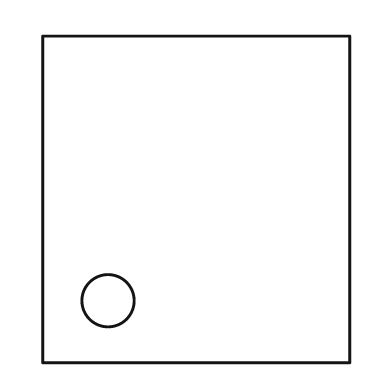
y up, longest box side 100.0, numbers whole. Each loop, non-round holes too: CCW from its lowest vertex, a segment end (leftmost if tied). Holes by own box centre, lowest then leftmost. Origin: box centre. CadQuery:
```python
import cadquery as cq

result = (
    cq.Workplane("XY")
    .moveTo(-47.0, -50.0)
    .lineTo(47.0, -50.0)
    .lineTo(47.0, 50.0)
    .lineTo(-47.0, 50.0)
    .close()
    .moveTo(-27.0, -31.0)
    .circle(8.0)
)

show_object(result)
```